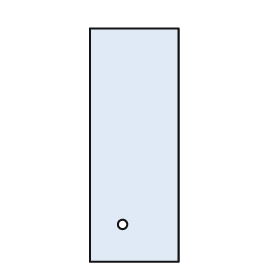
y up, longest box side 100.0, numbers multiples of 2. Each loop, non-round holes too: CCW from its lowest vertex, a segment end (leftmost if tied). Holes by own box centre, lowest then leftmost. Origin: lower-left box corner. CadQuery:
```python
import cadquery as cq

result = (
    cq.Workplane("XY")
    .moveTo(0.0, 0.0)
    .lineTo(38.0, 0.0)
    .lineTo(38.0, 100.0)
    .lineTo(0.0, 100.0)
    .close()
    .moveTo(14.0, 16.0)
    .circle(2.0)
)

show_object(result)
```